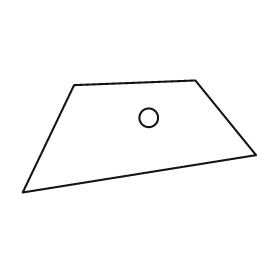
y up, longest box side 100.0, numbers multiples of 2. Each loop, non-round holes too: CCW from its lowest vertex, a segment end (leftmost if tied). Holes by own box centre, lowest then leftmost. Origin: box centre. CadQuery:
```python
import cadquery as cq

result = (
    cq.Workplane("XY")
    .moveTo(-50.0, -24.0)
    .lineTo(50.0, -8.0)
    .lineTo(24.0, 24.0)
    .lineTo(-28.0, 22.0)
    .close()
    .moveTo(4.0, 8.0)
    .circle(4.0)
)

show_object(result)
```